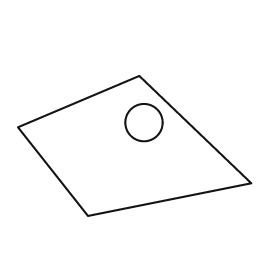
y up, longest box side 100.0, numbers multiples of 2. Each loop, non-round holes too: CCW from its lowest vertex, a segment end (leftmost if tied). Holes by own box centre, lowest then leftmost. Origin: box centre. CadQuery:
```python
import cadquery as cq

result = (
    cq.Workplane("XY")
    .moveTo(-20.0, -30.0)
    .lineTo(50.0, -16.0)
    .lineTo(2.0, 30.0)
    .lineTo(-50.0, 8.0)
    .close()
    .moveTo(4.0, 10.0)
    .circle(8.0)
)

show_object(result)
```